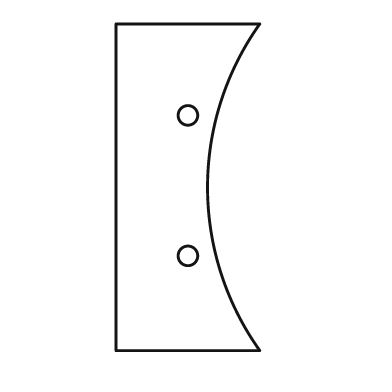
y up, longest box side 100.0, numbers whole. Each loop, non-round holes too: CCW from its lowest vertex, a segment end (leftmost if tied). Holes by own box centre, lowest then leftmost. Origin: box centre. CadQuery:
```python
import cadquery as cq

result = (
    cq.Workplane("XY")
    .moveTo(-22.0, -50.0)
    .lineTo(22.0, -50.0)
    .threePointArc((6.0, 0.0), (22.0, 50.0))
    .lineTo(-22.0, 50.0)
    .close()
    .moveTo(0.0, -21.0)
    .circle(3.0)
    .moveTo(0.0, 22.0)
    .circle(3.0)
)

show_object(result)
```